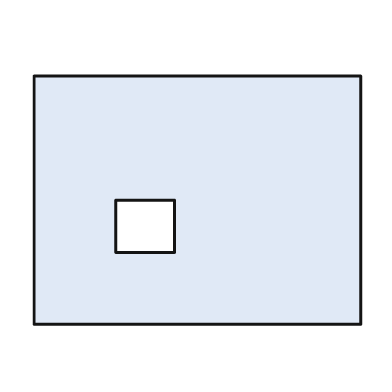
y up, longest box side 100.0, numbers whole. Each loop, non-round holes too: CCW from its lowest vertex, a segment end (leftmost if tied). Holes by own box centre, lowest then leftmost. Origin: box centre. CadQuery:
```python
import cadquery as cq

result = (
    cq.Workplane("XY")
    .moveTo(-50.0, -38.0)
    .lineTo(50.0, -38.0)
    .lineTo(50.0, 38.0)
    .lineTo(-50.0, 38.0)
    .close()
    .moveTo(-25.0, -16.0)
    .lineTo(-7.0, -16.0)
    .lineTo(-7.0, 0.0)
    .lineTo(-25.0, 0.0)
    .close()
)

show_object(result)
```